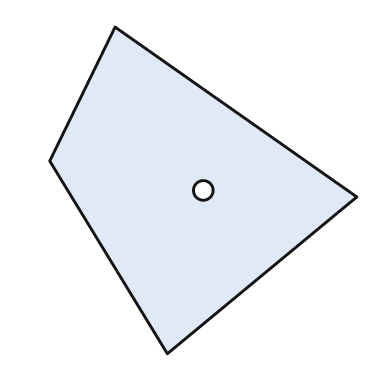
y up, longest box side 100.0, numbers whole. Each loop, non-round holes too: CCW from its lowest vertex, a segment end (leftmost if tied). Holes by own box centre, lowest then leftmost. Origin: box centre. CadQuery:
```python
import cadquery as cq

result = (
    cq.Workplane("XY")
    .moveTo(-11.0, -50.0)
    .lineTo(47.0, -2.0)
    .lineTo(-27.0, 50.0)
    .lineTo(-47.0, 9.0)
    .close()
    .moveTo(0.0, 0.0)
    .circle(3.0)
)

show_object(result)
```